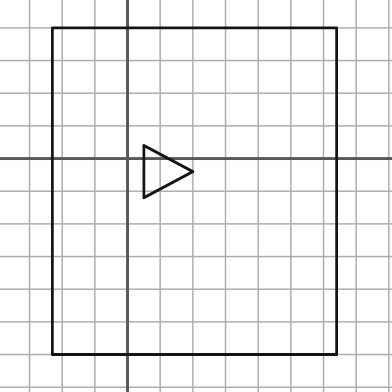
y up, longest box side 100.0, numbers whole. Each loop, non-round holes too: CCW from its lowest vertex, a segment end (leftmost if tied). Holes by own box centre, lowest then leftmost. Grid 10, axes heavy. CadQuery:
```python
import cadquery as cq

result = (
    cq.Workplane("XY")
    .moveTo(-23.0, -60.0)
    .lineTo(64.0, -60.0)
    .lineTo(64.0, 40.0)
    .lineTo(-23.0, 40.0)
    .close()
    .moveTo(5.0, -12.0)
    .lineTo(20.0, -4.0)
    .lineTo(5.0, 4.0)
    .close()
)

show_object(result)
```